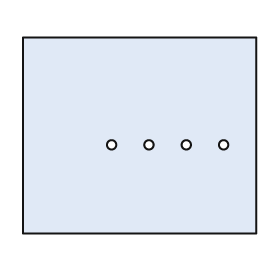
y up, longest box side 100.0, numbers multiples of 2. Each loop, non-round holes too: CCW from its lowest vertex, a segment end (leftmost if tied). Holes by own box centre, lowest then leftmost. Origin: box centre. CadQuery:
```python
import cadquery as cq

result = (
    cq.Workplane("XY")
    .moveTo(-50.0, -42.0)
    .lineTo(50.0, -42.0)
    .lineTo(50.0, 42.0)
    .lineTo(-50.0, 42.0)
    .close()
    .moveTo(-12.0, -4.0)
    .circle(2.0)
    .moveTo(4.0, -4.0)
    .circle(2.0)
    .moveTo(20.0, -4.0)
    .circle(2.0)
    .moveTo(36.0, -4.0)
    .circle(2.0)
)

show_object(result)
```